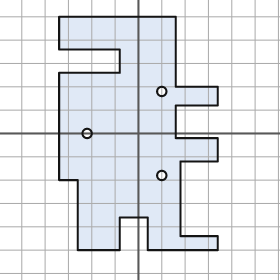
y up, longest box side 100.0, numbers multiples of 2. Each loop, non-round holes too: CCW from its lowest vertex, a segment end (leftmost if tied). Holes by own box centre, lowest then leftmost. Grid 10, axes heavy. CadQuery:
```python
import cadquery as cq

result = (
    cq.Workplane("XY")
    .moveTo(-26.0, -50.0)
    .lineTo(-8.0, -50.0)
    .lineTo(-8.0, -36.0)
    .lineTo(4.0, -36.0)
    .lineTo(4.0, -50.0)
    .lineTo(34.0, -50.0)
    .lineTo(34.0, -44.0)
    .lineTo(18.0, -44.0)
    .lineTo(18.0, -12.0)
    .lineTo(34.0, -12.0)
    .lineTo(34.0, -2.0)
    .lineTo(16.0, -2.0)
    .lineTo(16.0, 12.0)
    .lineTo(34.0, 12.0)
    .lineTo(34.0, 20.0)
    .lineTo(16.0, 20.0)
    .lineTo(16.0, 50.0)
    .lineTo(-34.0, 50.0)
    .lineTo(-34.0, 36.0)
    .lineTo(-8.0, 36.0)
    .lineTo(-8.0, 26.0)
    .lineTo(-34.0, 26.0)
    .lineTo(-34.0, -20.0)
    .lineTo(-26.0, -20.0)
    .close()
    .moveTo(10.0, -18.0)
    .circle(2.0)
    .moveTo(-22.0, 0.0)
    .circle(2.0)
    .moveTo(10.0, 18.0)
    .circle(2.0)
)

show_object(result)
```